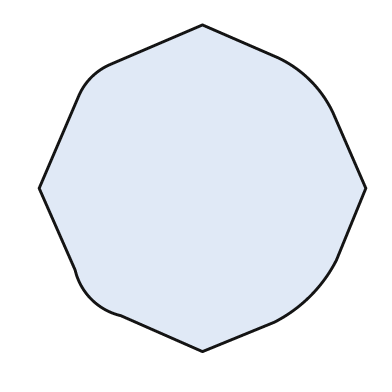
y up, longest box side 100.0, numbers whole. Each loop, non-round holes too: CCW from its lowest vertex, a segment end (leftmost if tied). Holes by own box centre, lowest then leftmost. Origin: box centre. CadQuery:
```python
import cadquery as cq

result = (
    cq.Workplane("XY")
    .moveTo(0.0, -50.0)
    .lineTo(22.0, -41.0)
    .threePointArc((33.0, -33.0), (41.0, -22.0))
    .lineTo(50.0, 0.0)
    .lineTo(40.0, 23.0)
    .threePointArc((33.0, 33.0), (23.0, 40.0))
    .lineTo(0.0, 50.0)
    .lineTo(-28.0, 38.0)
    .threePointArc((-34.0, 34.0), (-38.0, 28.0))
    .lineTo(-50.0, 0.0)
    .lineTo(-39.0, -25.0)
    .threePointArc((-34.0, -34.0), (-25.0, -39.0))
    .close()
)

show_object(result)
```